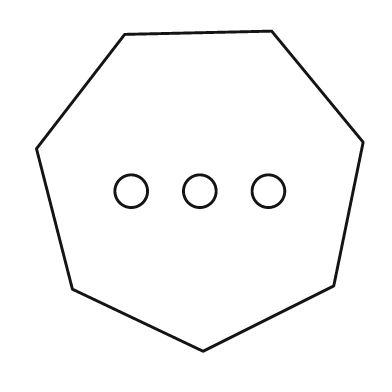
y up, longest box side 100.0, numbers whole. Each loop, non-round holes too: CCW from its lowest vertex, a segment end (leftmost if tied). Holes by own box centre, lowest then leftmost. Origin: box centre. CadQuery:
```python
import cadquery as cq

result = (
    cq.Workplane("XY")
    .moveTo(1.0, -49.0)
    .lineTo(41.0, -29.0)
    .lineTo(50.0, 15.0)
    .lineTo(22.0, 49.0)
    .lineTo(-23.0, 48.0)
    .lineTo(-50.0, 13.0)
    .lineTo(-39.0, -30.0)
    .close()
    .moveTo(-21.0, 0.0)
    .circle(5.0)
    .moveTo(0.0, 0.0)
    .circle(5.0)
    .moveTo(21.0, 0.0)
    .circle(5.0)
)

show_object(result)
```